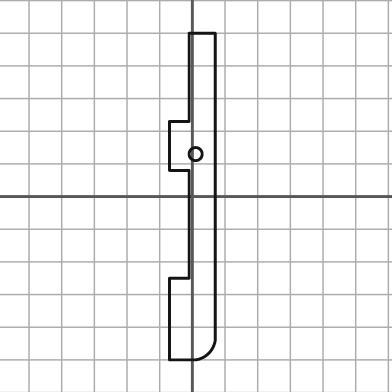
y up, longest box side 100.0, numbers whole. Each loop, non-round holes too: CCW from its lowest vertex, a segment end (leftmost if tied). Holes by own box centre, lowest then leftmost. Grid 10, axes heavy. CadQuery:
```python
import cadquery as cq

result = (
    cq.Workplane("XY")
    .moveTo(-7.0, -50.0)
    .lineTo(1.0, -50.0)
    .threePointArc((5.0, -48.0), (7.0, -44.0))
    .lineTo(7.0, 50.0)
    .lineTo(-1.0, 50.0)
    .lineTo(-1.0, 23.0)
    .lineTo(-7.0, 23.0)
    .lineTo(-7.0, 8.0)
    .lineTo(-1.0, 8.0)
    .lineTo(-1.0, -25.0)
    .lineTo(-7.0, -25.0)
    .close()
    .moveTo(1.0, 13.0)
    .circle(2.0)
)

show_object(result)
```